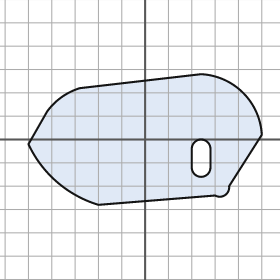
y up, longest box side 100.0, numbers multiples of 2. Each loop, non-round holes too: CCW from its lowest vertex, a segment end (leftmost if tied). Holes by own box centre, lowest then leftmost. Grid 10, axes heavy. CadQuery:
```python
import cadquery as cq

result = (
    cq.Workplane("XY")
    .moveTo(-20.0, -28.0)
    .lineTo(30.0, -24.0)
    .threePointArc((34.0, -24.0), (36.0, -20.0))
    .lineTo(50.0, 2.0)
    .threePointArc((42.0, 20.0), (24.0, 28.0))
    .lineTo(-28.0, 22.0)
    .threePointArc((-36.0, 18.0), (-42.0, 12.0))
    .lineTo(-50.0, -2.0)
    .threePointArc((-38.0, -18.0), (-20.0, -28.0))
    .close()
    .moveTo(20.0, -12.0)
    .threePointArc((24.0, -16.0), (28.0, -12.0))
    .lineTo(28.0, -4.0)
    .threePointArc((24.0, 0.0), (20.0, -4.0))
    .close()
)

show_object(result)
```